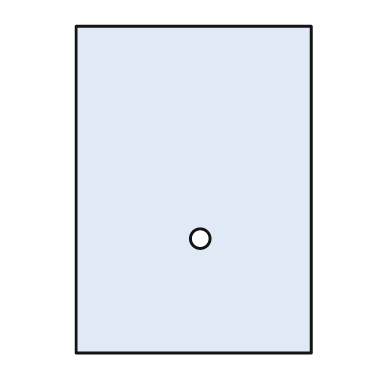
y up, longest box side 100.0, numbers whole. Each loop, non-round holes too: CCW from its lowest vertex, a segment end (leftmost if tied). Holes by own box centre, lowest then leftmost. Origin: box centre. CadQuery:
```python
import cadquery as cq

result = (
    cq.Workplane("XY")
    .moveTo(-36.0, -50.0)
    .lineTo(36.0, -50.0)
    .lineTo(36.0, 50.0)
    .lineTo(-36.0, 50.0)
    .close()
    .moveTo(2.0, -15.0)
    .circle(3.0)
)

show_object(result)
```